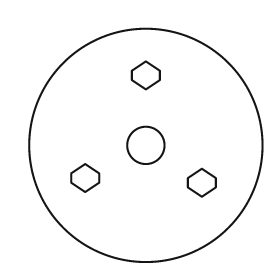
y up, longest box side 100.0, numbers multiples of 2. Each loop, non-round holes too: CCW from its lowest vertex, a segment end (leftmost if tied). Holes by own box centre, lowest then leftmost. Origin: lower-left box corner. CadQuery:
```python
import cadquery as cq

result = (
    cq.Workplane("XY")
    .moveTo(50.0, 50.0)
    .circle(50.0)
    .moveTo(74.0, 28.0)
    .lineTo(80.0, 32.0)
    .lineTo(80.0, 36.0)
    .lineTo(74.0, 40.0)
    .lineTo(68.0, 36.0)
    .lineTo(68.0, 32.0)
    .close()
    .moveTo(24.0, 30.0)
    .lineTo(30.0, 34.0)
    .lineTo(30.0, 38.0)
    .lineTo(24.0, 42.0)
    .lineTo(18.0, 38.0)
    .lineTo(18.0, 34.0)
    .close()
    .moveTo(50.0, 50.0)
    .circle(8.0)
    .moveTo(50.0, 74.0)
    .lineTo(56.0, 78.0)
    .lineTo(56.0, 82.0)
    .lineTo(50.0, 86.0)
    .lineTo(44.0, 82.0)
    .lineTo(44.0, 78.0)
    .close()
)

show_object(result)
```